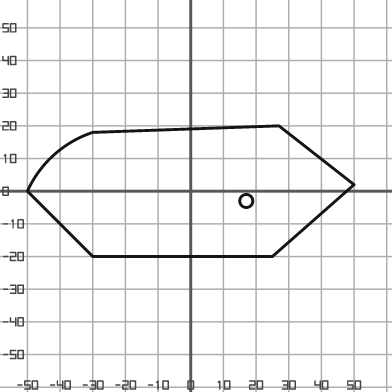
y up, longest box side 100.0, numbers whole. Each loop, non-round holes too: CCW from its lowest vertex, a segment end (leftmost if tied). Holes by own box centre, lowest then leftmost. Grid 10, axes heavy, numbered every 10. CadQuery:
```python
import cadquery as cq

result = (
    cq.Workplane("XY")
    .moveTo(-30.0, -20.0)
    .lineTo(25.0, -20.0)
    .lineTo(50.0, 2.0)
    .lineTo(27.0, 20.0)
    .lineTo(-30.0, 18.0)
    .threePointArc((-42.0, 11.0), (-50.0, 0.0))
    .close()
    .moveTo(17.0, -3.0)
    .circle(2.0)
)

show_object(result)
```